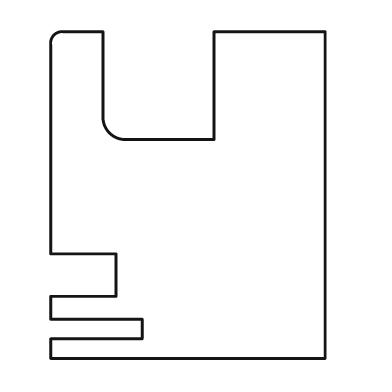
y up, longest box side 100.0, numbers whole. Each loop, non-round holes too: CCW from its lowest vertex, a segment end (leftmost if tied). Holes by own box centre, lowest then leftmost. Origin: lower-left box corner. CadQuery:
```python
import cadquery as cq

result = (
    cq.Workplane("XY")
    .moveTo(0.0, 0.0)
    .lineTo(84.0, 0.0)
    .lineTo(84.0, 100.0)
    .lineTo(50.0, 100.0)
    .lineTo(50.0, 67.0)
    .lineTo(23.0, 67.0)
    .threePointArc((18.0, 69.0), (16.0, 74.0))
    .lineTo(16.0, 100.0)
    .lineTo(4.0, 100.0)
    .threePointArc((1.0, 99.0), (0.0, 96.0))
    .lineTo(0.0, 32.0)
    .lineTo(20.0, 32.0)
    .lineTo(20.0, 19.0)
    .lineTo(0.0, 19.0)
    .lineTo(0.0, 12.0)
    .lineTo(28.0, 12.0)
    .lineTo(28.0, 6.0)
    .lineTo(0.0, 6.0)
    .close()
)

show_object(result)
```